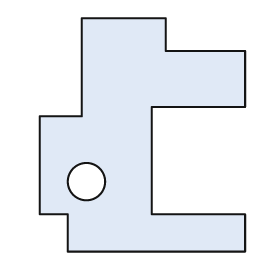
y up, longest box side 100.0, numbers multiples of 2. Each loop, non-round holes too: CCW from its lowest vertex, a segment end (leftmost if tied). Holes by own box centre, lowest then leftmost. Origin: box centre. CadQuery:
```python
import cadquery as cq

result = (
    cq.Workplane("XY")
    .moveTo(-32.0, -50.0)
    .lineTo(44.0, -50.0)
    .lineTo(44.0, -34.0)
    .lineTo(4.0, -34.0)
    .lineTo(4.0, 12.0)
    .lineTo(44.0, 12.0)
    .lineTo(44.0, 36.0)
    .lineTo(10.0, 36.0)
    .lineTo(10.0, 50.0)
    .lineTo(-26.0, 50.0)
    .lineTo(-26.0, 8.0)
    .lineTo(-44.0, 8.0)
    .lineTo(-44.0, -34.0)
    .lineTo(-32.0, -34.0)
    .close()
    .moveTo(-24.0, -20.0)
    .circle(8.0)
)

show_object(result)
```